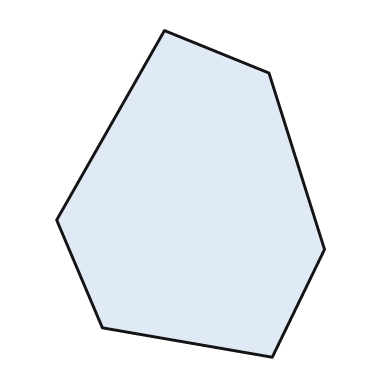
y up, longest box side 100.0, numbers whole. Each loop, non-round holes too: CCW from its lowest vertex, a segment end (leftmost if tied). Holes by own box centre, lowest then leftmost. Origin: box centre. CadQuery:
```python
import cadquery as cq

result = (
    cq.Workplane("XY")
    .moveTo(25.0, -50.0)
    .lineTo(41.0, -17.0)
    .lineTo(24.0, 37.0)
    .lineTo(-8.0, 50.0)
    .lineTo(-41.0, -8.0)
    .lineTo(-27.0, -41.0)
    .close()
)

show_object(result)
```